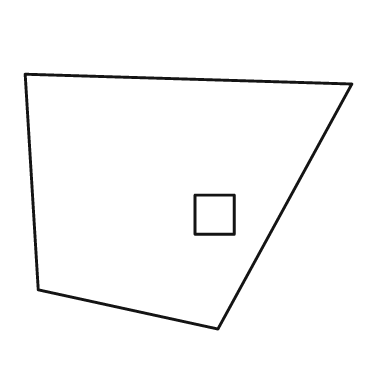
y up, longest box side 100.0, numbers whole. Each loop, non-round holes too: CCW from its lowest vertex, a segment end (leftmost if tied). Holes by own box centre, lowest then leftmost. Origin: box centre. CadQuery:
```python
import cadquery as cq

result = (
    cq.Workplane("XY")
    .moveTo(9.0, -39.0)
    .lineTo(50.0, 36.0)
    .lineTo(-50.0, 39.0)
    .lineTo(-46.0, -27.0)
    .close()
    .moveTo(2.0, -10.0)
    .lineTo(14.0, -10.0)
    .lineTo(14.0, 2.0)
    .lineTo(2.0, 2.0)
    .close()
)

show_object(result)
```